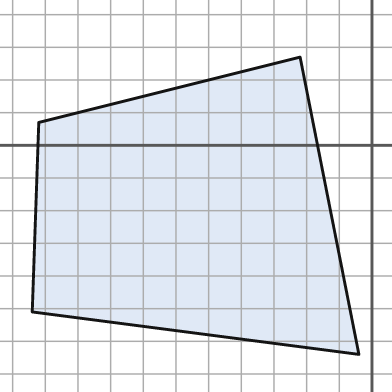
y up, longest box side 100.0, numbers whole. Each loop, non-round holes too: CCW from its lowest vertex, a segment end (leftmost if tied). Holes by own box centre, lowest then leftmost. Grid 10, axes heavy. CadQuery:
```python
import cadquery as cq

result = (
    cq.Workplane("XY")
    .moveTo(-4.0, -64.0)
    .lineTo(-22.0, 27.0)
    .lineTo(-102.0, 7.0)
    .lineTo(-104.0, -51.0)
    .close()
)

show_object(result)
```